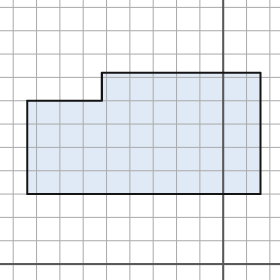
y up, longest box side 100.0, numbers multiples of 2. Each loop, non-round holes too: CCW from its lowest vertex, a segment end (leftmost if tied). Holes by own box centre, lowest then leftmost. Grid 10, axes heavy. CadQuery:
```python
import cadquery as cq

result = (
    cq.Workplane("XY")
    .moveTo(-84.0, 30.0)
    .lineTo(16.0, 30.0)
    .lineTo(16.0, 82.0)
    .lineTo(-52.0, 82.0)
    .lineTo(-52.0, 70.0)
    .lineTo(-84.0, 70.0)
    .close()
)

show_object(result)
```